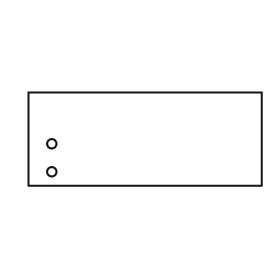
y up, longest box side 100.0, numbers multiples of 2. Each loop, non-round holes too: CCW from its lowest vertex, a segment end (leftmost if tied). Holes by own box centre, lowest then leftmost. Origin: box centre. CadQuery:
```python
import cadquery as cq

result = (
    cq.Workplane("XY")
    .moveTo(-50.0, -20.0)
    .lineTo(50.0, -20.0)
    .lineTo(50.0, 20.0)
    .lineTo(-50.0, 20.0)
    .close()
    .moveTo(-40.0, -14.0)
    .circle(2.0)
    .moveTo(-40.0, -2.0)
    .circle(2.0)
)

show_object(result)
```